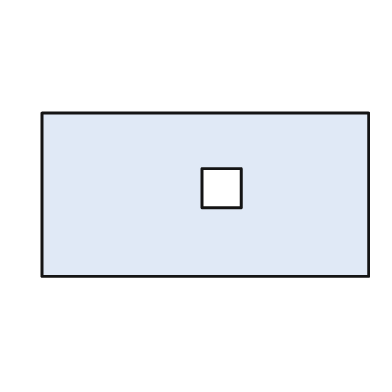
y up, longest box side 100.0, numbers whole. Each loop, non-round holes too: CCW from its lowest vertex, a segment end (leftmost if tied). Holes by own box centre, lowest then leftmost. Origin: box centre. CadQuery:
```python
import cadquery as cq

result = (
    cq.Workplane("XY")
    .moveTo(-50.0, -25.0)
    .lineTo(50.0, -25.0)
    .lineTo(50.0, 25.0)
    .lineTo(-50.0, 25.0)
    .close()
    .moveTo(-1.0, -4.0)
    .lineTo(11.0, -4.0)
    .lineTo(11.0, 8.0)
    .lineTo(-1.0, 8.0)
    .close()
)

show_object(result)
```